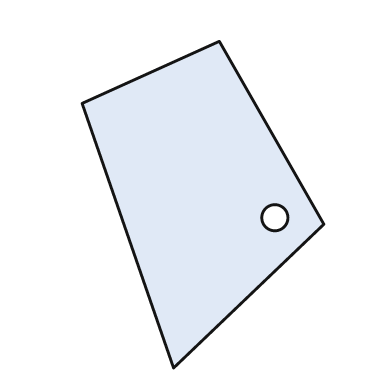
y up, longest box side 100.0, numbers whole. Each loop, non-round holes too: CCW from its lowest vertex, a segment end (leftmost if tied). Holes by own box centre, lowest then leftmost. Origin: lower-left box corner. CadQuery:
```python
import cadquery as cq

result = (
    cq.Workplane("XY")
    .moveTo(28.0, 0.0)
    .lineTo(74.0, 44.0)
    .lineTo(42.0, 100.0)
    .lineTo(0.0, 81.0)
    .close()
    .moveTo(59.0, 46.0)
    .circle(4.0)
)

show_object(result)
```